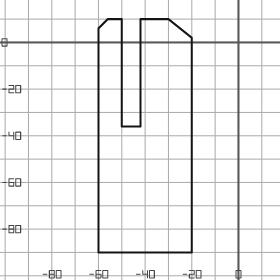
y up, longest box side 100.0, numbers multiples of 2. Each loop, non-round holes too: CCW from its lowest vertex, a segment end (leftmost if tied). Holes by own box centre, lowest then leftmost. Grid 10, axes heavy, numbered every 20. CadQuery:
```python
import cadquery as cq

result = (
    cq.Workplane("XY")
    .moveTo(-60.0, -90.0)
    .lineTo(-20.0, -90.0)
    .lineTo(-20.0, 2.0)
    .lineTo(-30.0, 10.0)
    .lineTo(-42.0, 10.0)
    .lineTo(-42.0, -36.0)
    .lineTo(-50.0, -36.0)
    .lineTo(-50.0, 10.0)
    .lineTo(-56.0, 10.0)
    .lineTo(-60.0, 6.0)
    .close()
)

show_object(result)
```